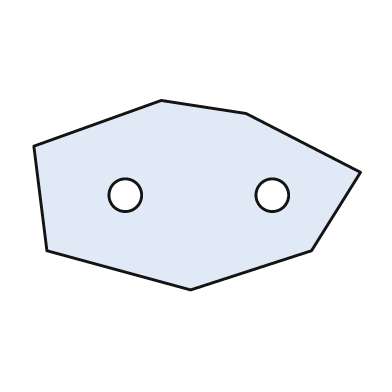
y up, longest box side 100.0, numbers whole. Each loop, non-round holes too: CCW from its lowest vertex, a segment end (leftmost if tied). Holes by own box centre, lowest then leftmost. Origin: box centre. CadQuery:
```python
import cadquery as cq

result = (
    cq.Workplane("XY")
    .moveTo(-2.0, -29.0)
    .lineTo(35.0, -17.0)
    .lineTo(50.0, 7.0)
    .lineTo(15.0, 25.0)
    .lineTo(-11.0, 29.0)
    .lineTo(-50.0, 15.0)
    .lineTo(-46.0, -17.0)
    .close()
    .moveTo(-22.0, 0.0)
    .circle(5.0)
    .moveTo(23.0, 0.0)
    .circle(5.0)
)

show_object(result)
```